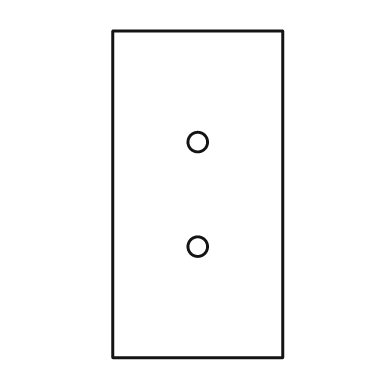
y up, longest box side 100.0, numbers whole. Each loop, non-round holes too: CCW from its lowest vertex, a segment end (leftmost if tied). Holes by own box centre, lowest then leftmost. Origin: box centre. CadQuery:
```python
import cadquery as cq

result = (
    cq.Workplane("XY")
    .moveTo(-26.0, -50.0)
    .lineTo(26.0, -50.0)
    .lineTo(26.0, 50.0)
    .lineTo(-26.0, 50.0)
    .close()
    .moveTo(0.0, -16.0)
    .circle(3.0)
    .moveTo(0.0, 16.0)
    .circle(3.0)
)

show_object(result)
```